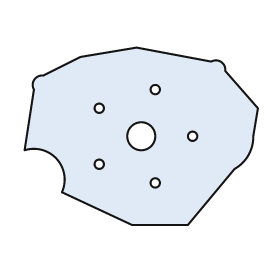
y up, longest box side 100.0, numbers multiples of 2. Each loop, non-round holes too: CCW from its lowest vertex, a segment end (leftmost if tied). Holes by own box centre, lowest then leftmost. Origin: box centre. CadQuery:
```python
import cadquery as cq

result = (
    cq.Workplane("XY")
    .moveTo(-4.0, -38.0)
    .lineTo(20.0, -38.0)
    .lineTo(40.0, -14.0)
    .threePointArc((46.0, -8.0), (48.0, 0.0))
    .lineTo(50.0, 12.0)
    .lineTo(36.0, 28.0)
    .threePointArc((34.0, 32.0), (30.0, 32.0))
    .lineTo(-2.0, 38.0)
    .lineTo(-26.0, 34.0)
    .lineTo(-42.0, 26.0)
    .threePointArc((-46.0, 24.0), (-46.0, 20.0))
    .lineTo(-50.0, -6.0)
    .threePointArc((-36.0, -10.0), (-34.0, -24.0))
    .close()
    .moveTo(6.0, -20.0)
    .circle(2.0)
    .moveTo(-18.0, -12.0)
    .circle(2.0)
    .moveTo(0.0, 0.0)
    .circle(6.0)
    .moveTo(22.0, 0.0)
    .circle(2.0)
    .moveTo(-18.0, 12.0)
    .circle(2.0)
    .moveTo(6.0, 20.0)
    .circle(2.0)
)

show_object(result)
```